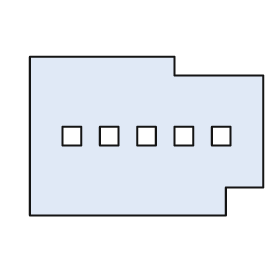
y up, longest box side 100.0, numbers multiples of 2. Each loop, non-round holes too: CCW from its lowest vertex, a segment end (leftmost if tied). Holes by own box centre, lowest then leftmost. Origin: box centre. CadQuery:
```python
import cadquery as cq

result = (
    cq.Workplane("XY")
    .moveTo(-50.0, -34.0)
    .lineTo(34.0, -34.0)
    .lineTo(34.0, -22.0)
    .lineTo(50.0, -22.0)
    .lineTo(50.0, 26.0)
    .lineTo(12.0, 26.0)
    .lineTo(12.0, 34.0)
    .lineTo(-50.0, 34.0)
    .close()
    .moveTo(-36.0, -4.0)
    .lineTo(-28.0, -4.0)
    .lineTo(-28.0, 4.0)
    .lineTo(-36.0, 4.0)
    .close()
    .moveTo(-20.0, -4.0)
    .lineTo(-12.0, -4.0)
    .lineTo(-12.0, 4.0)
    .lineTo(-20.0, 4.0)
    .close()
    .moveTo(-4.0, -4.0)
    .lineTo(4.0, -4.0)
    .lineTo(4.0, 4.0)
    .lineTo(-4.0, 4.0)
    .close()
    .moveTo(12.0, -4.0)
    .lineTo(20.0, -4.0)
    .lineTo(20.0, 4.0)
    .lineTo(12.0, 4.0)
    .close()
    .moveTo(28.0, -4.0)
    .lineTo(36.0, -4.0)
    .lineTo(36.0, 4.0)
    .lineTo(28.0, 4.0)
    .close()
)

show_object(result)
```